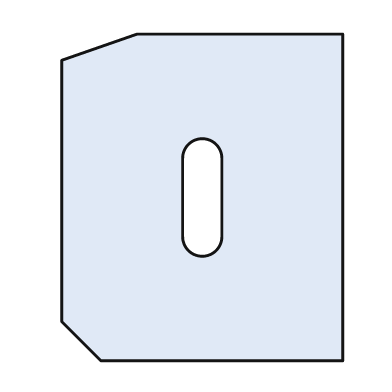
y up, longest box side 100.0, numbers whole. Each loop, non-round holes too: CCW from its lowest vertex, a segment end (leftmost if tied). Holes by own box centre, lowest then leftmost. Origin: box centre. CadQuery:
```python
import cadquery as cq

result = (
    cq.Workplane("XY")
    .moveTo(-31.0, -50.0)
    .lineTo(43.0, -50.0)
    .lineTo(43.0, 50.0)
    .lineTo(-20.0, 50.0)
    .lineTo(-43.0, 42.0)
    .lineTo(-43.0, -38.0)
    .close()
    .moveTo(-6.0, -12.0)
    .threePointArc((0.0, -18.0), (6.0, -12.0))
    .lineTo(6.0, 12.0)
    .threePointArc((0.0, 18.0), (-6.0, 12.0))
    .close()
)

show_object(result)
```